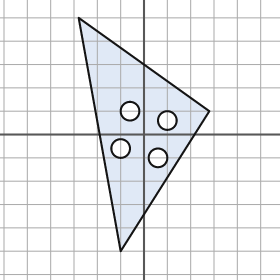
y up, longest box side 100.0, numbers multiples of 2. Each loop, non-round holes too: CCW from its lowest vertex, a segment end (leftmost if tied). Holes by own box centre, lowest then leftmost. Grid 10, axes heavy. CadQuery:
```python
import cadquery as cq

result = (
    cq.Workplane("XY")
    .moveTo(-10.0, -50.0)
    .lineTo(28.0, 10.0)
    .lineTo(-28.0, 50.0)
    .close()
    .moveTo(6.0, -10.0)
    .circle(4.0)
    .moveTo(-10.0, -6.0)
    .circle(4.0)
    .moveTo(10.0, 6.0)
    .circle(4.0)
    .moveTo(-6.0, 10.0)
    .circle(4.0)
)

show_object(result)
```